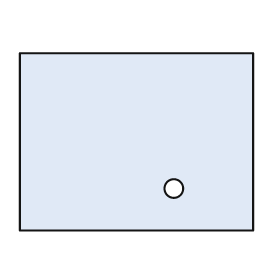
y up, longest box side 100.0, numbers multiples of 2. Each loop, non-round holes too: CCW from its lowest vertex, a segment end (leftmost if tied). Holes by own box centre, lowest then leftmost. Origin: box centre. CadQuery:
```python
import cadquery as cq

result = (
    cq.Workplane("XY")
    .moveTo(-50.0, -38.0)
    .lineTo(50.0, -38.0)
    .lineTo(50.0, 38.0)
    .lineTo(-50.0, 38.0)
    .close()
    .moveTo(16.0, -20.0)
    .circle(4.0)
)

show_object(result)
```